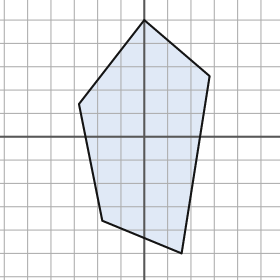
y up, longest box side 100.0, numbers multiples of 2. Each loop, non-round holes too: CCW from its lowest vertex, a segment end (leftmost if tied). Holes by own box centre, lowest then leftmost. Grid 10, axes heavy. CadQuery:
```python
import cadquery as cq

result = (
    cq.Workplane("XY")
    .moveTo(16.0, -50.0)
    .lineTo(28.0, 26.0)
    .lineTo(0.0, 50.0)
    .lineTo(-28.0, 14.0)
    .lineTo(-18.0, -36.0)
    .close()
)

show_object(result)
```